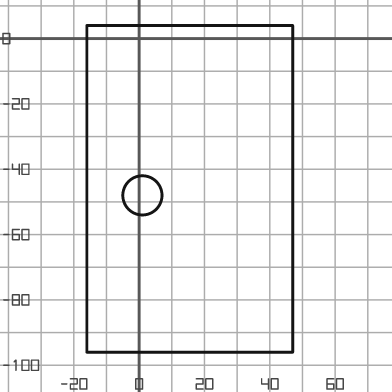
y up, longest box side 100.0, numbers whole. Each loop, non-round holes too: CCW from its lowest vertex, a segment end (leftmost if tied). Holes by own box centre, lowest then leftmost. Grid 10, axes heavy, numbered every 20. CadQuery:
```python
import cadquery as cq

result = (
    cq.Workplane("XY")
    .moveTo(-16.0, -96.0)
    .lineTo(47.0, -96.0)
    .lineTo(47.0, 4.0)
    .lineTo(-16.0, 4.0)
    .close()
    .moveTo(1.0, -48.0)
    .circle(6.0)
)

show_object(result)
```